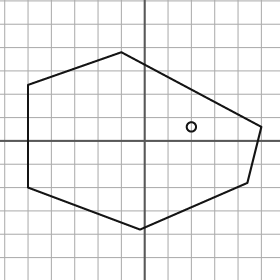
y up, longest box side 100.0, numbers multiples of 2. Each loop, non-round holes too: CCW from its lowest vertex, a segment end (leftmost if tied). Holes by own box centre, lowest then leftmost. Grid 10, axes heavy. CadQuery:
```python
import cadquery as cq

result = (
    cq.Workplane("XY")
    .moveTo(-2.0, -38.0)
    .lineTo(44.0, -18.0)
    .lineTo(50.0, 6.0)
    .lineTo(-10.0, 38.0)
    .lineTo(-50.0, 24.0)
    .lineTo(-50.0, -20.0)
    .close()
    .moveTo(20.0, 6.0)
    .circle(2.0)
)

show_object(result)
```